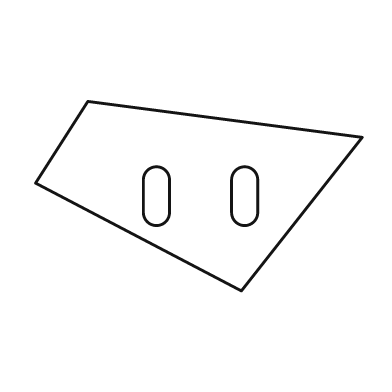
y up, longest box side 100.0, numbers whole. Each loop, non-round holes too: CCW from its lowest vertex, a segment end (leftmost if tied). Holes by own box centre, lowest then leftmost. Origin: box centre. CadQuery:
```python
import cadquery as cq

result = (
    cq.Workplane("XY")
    .moveTo(13.0, -29.0)
    .lineTo(50.0, 18.0)
    .lineTo(-34.0, 29.0)
    .lineTo(-50.0, 4.0)
    .close()
    .moveTo(-17.0, -5.0)
    .threePointArc((-13.0, -9.0), (-9.0, -5.0))
    .lineTo(-9.0, 5.0)
    .threePointArc((-13.0, 9.0), (-17.0, 5.0))
    .close()
    .moveTo(10.0, -5.0)
    .threePointArc((14.0, -9.0), (18.0, -5.0))
    .lineTo(18.0, 5.0)
    .threePointArc((14.0, 9.0), (10.0, 5.0))
    .close()
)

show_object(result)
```